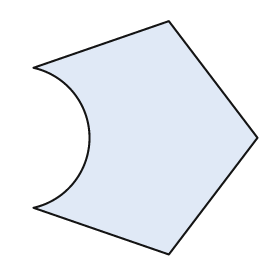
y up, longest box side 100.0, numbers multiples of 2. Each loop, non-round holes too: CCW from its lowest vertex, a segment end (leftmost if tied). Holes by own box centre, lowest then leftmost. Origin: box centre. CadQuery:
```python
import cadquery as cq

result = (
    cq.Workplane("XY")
    .moveTo(10.0, -50.0)
    .lineTo(48.0, 0.0)
    .lineTo(10.0, 50.0)
    .lineTo(-48.0, 30.0)
    .threePointArc((-24.0, 0.0), (-48.0, -30.0))
    .close()
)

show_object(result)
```